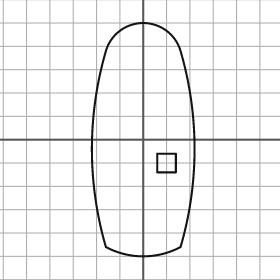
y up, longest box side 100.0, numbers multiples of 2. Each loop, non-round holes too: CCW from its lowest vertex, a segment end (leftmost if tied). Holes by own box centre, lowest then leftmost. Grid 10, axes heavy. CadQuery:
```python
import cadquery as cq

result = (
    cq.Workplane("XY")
    .moveTo(-16.0, -46.0)
    .threePointArc((0.0, -50.0), (16.0, -46.0))
    .threePointArc((22.0, -4.0), (16.0, 38.0))
    .threePointArc((0.0, 50.0), (-16.0, 38.0))
    .threePointArc((-22.0, -4.0), (-16.0, -46.0))
    .close()
    .moveTo(6.0, -14.0)
    .lineTo(14.0, -14.0)
    .lineTo(14.0, -6.0)
    .lineTo(6.0, -6.0)
    .close()
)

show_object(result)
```